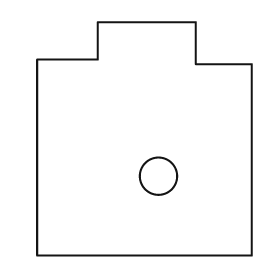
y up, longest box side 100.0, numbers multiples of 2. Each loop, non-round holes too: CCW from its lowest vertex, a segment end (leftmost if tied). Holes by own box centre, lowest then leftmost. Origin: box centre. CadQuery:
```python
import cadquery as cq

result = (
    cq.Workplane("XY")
    .moveTo(-46.0, -50.0)
    .lineTo(46.0, -50.0)
    .lineTo(46.0, 32.0)
    .lineTo(22.0, 32.0)
    .lineTo(22.0, 50.0)
    .lineTo(-20.0, 50.0)
    .lineTo(-20.0, 34.0)
    .lineTo(-46.0, 34.0)
    .close()
    .moveTo(6.0, -16.0)
    .circle(8.0)
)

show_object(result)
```